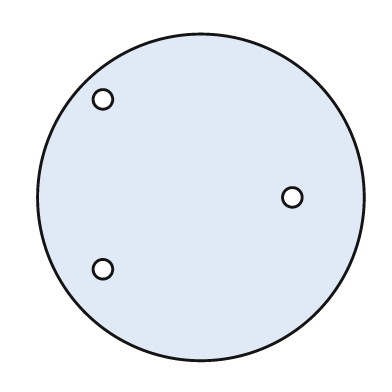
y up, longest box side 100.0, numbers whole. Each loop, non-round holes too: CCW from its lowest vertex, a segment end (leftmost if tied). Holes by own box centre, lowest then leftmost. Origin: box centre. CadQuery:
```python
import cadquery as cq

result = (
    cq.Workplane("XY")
    .moveTo(0.0, 0.0)
    .circle(50.0)
    .moveTo(-30.0, -22.0)
    .circle(3.0)
    .moveTo(28.0, 0.0)
    .circle(3.0)
    .moveTo(-30.0, 30.0)
    .circle(3.0)
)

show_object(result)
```